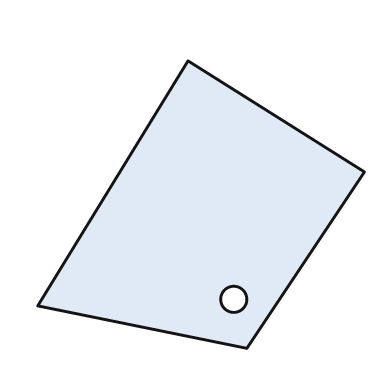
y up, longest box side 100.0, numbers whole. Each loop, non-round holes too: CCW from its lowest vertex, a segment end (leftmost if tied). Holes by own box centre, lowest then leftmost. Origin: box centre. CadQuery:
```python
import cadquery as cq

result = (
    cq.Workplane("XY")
    .moveTo(14.0, -44.0)
    .lineTo(50.0, 10.0)
    .lineTo(-4.0, 44.0)
    .lineTo(-50.0, -31.0)
    .close()
    .moveTo(10.0, -29.0)
    .circle(4.0)
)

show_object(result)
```